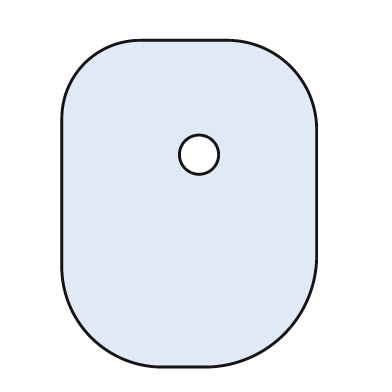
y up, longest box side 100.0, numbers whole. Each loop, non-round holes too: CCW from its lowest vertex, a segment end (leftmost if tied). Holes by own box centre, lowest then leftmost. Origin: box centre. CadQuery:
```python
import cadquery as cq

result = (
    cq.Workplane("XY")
    .moveTo(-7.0, -50.0)
    .lineTo(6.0, -50.0)
    .threePointArc((29.0, -40.0), (39.0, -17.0))
    .lineTo(39.0, 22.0)
    .threePointArc((31.0, 42.0), (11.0, 50.0))
    .lineTo(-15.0, 50.0)
    .threePointArc((-32.0, 43.0), (-39.0, 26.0))
    .lineTo(-39.0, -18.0)
    .threePointArc((-30.0, -41.0), (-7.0, -50.0))
    .close()
    .moveTo(3.0, 15.0)
    .circle(6.0)
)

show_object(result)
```